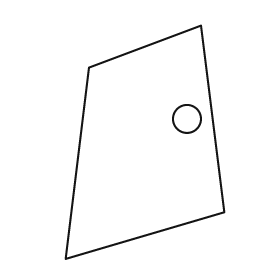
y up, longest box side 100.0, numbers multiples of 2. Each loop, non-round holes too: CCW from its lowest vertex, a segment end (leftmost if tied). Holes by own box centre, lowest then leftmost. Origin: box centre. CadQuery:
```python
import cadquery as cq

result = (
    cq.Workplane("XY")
    .moveTo(-34.0, -50.0)
    .lineTo(34.0, -30.0)
    .lineTo(24.0, 50.0)
    .lineTo(-24.0, 32.0)
    .close()
    .moveTo(18.0, 10.0)
    .circle(6.0)
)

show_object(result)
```